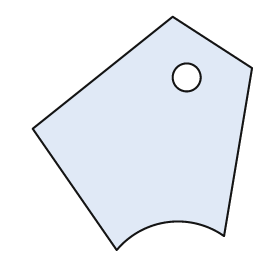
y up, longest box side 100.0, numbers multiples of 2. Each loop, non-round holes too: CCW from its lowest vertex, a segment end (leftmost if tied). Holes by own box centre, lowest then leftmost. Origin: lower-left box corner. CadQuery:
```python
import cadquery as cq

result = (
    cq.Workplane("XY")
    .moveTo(36.0, 0.0)
    .threePointArc((58.0, 12.0), (82.0, 6.0))
    .lineTo(94.0, 78.0)
    .lineTo(60.0, 100.0)
    .lineTo(0.0, 52.0)
    .close()
    .moveTo(66.0, 74.0)
    .circle(6.0)
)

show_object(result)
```